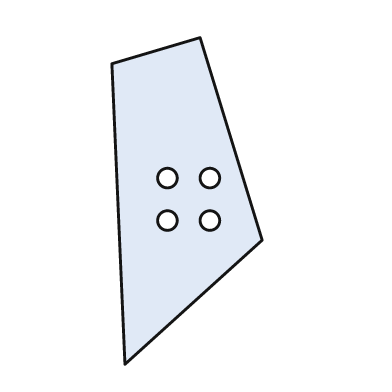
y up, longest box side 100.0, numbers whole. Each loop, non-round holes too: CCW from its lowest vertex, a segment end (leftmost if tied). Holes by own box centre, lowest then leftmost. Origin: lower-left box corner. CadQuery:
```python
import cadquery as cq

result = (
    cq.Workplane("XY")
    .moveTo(4.0, 0.0)
    .lineTo(46.0, 38.0)
    .lineTo(27.0, 100.0)
    .lineTo(0.0, 92.0)
    .close()
    .moveTo(17.0, 44.0)
    .circle(3.0)
    .moveTo(30.0, 44.0)
    .circle(3.0)
    .moveTo(17.0, 57.0)
    .circle(3.0)
    .moveTo(30.0, 57.0)
    .circle(3.0)
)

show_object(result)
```